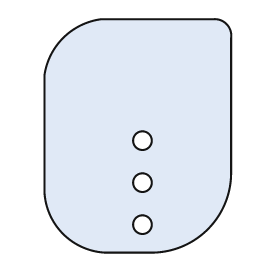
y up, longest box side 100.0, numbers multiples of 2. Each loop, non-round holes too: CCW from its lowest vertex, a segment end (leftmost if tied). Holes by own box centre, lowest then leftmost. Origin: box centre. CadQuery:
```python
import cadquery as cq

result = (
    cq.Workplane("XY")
    .moveTo(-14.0, -50.0)
    .lineTo(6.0, -50.0)
    .threePointArc((30.0, -40.0), (40.0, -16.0))
    .lineTo(40.0, 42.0)
    .threePointArc((38.0, 48.0), (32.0, 50.0))
    .lineTo(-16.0, 50.0)
    .threePointArc((-32.0, 42.0), (-40.0, 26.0))
    .lineTo(-40.0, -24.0)
    .threePointArc((-32.0, -42.0), (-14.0, -50.0))
    .close()
    .moveTo(2.0, -38.0)
    .circle(4.0)
    .moveTo(2.0, -20.0)
    .circle(4.0)
    .moveTo(2.0, -2.0)
    .circle(4.0)
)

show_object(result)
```